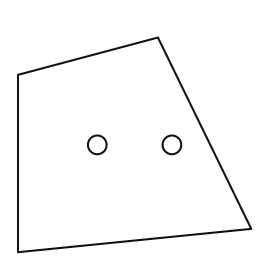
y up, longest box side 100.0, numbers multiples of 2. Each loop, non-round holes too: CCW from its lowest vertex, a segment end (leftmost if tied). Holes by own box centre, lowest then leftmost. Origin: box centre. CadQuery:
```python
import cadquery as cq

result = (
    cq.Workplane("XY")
    .moveTo(-50.0, -46.0)
    .lineTo(50.0, -36.0)
    .lineTo(10.0, 46.0)
    .lineTo(-50.0, 30.0)
    .close()
    .moveTo(-16.0, 0.0)
    .circle(4.0)
    .moveTo(16.0, 0.0)
    .circle(4.0)
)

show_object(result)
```